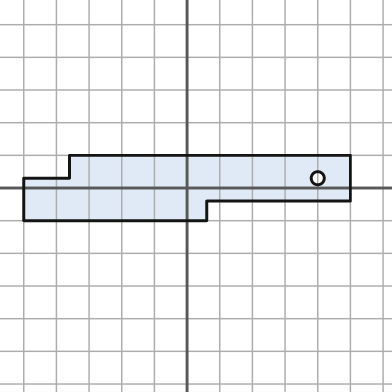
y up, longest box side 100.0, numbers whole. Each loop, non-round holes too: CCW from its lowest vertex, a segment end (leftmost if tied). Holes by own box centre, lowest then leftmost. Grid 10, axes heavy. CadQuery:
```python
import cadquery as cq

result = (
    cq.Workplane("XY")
    .moveTo(-50.0, -10.0)
    .lineTo(6.0, -10.0)
    .lineTo(6.0, -4.0)
    .lineTo(50.0, -4.0)
    .lineTo(50.0, 10.0)
    .lineTo(-36.0, 10.0)
    .lineTo(-36.0, 3.0)
    .lineTo(-50.0, 3.0)
    .close()
    .moveTo(40.0, 3.0)
    .circle(2.0)
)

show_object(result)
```